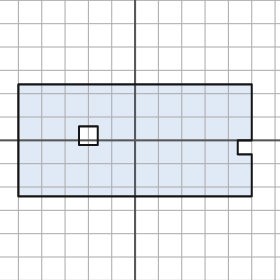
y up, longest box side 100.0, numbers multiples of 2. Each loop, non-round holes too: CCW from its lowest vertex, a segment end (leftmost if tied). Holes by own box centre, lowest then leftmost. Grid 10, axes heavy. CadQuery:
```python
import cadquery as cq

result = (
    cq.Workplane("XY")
    .moveTo(-50.0, -24.0)
    .lineTo(50.0, -24.0)
    .lineTo(50.0, -6.0)
    .lineTo(44.0, -6.0)
    .lineTo(44.0, 0.0)
    .lineTo(50.0, 0.0)
    .lineTo(50.0, 24.0)
    .lineTo(-50.0, 24.0)
    .close()
    .moveTo(-24.0, -2.0)
    .lineTo(-16.0, -2.0)
    .lineTo(-16.0, 6.0)
    .lineTo(-24.0, 6.0)
    .close()
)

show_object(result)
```